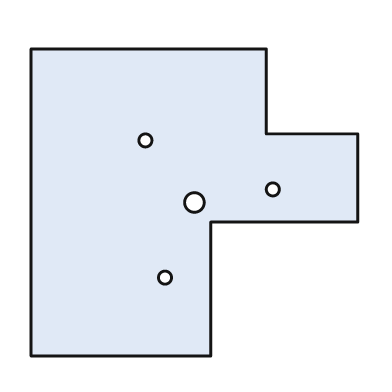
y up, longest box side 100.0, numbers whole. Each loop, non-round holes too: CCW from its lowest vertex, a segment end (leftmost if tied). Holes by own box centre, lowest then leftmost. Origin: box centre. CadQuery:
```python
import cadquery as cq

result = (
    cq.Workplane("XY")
    .moveTo(-50.0, -47.0)
    .lineTo(5.0, -47.0)
    .lineTo(5.0, -6.0)
    .lineTo(50.0, -6.0)
    .lineTo(50.0, 21.0)
    .lineTo(22.0, 21.0)
    .lineTo(22.0, 47.0)
    .lineTo(-50.0, 47.0)
    .close()
    .moveTo(-9.0, -23.0)
    .circle(2.0)
    .moveTo(0.0, 0.0)
    .circle(3.0)
    .moveTo(24.0, 4.0)
    .circle(2.0)
    .moveTo(-15.0, 19.0)
    .circle(2.0)
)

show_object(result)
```